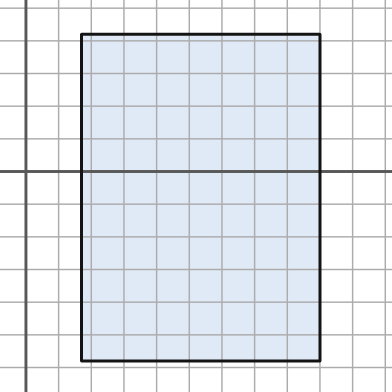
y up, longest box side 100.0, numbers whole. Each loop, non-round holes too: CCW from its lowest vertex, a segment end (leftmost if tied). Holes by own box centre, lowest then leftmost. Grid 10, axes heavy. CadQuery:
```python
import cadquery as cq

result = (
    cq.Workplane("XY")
    .moveTo(17.0, -58.0)
    .lineTo(90.0, -58.0)
    .lineTo(90.0, 42.0)
    .lineTo(17.0, 42.0)
    .close()
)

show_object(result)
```